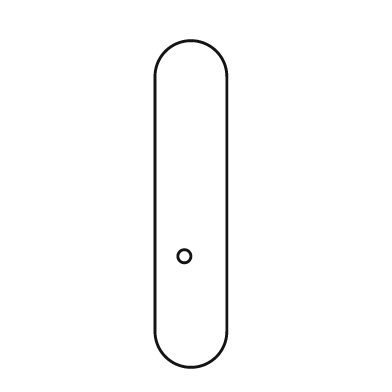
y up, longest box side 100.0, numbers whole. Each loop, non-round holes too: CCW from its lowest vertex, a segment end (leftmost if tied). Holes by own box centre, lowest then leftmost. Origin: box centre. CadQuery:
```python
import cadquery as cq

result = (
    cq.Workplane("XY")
    .moveTo(-11.0, -39.0)
    .threePointArc((0.0, -50.0), (11.0, -39.0))
    .lineTo(11.0, 39.0)
    .threePointArc((0.0, 50.0), (-11.0, 39.0))
    .close()
    .moveTo(-2.0, -16.0)
    .circle(2.0)
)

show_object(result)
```